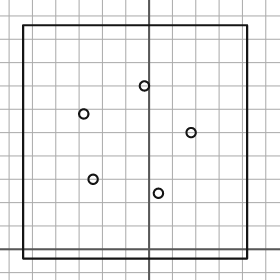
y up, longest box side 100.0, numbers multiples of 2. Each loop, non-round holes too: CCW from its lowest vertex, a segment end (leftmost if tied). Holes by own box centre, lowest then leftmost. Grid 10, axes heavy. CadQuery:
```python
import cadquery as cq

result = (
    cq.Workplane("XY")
    .moveTo(-54.0, -4.0)
    .lineTo(42.0, -4.0)
    .lineTo(42.0, 96.0)
    .lineTo(-54.0, 96.0)
    .close()
    .moveTo(4.0, 24.0)
    .circle(2.0)
    .moveTo(-24.0, 30.0)
    .circle(2.0)
    .moveTo(18.0, 50.0)
    .circle(2.0)
    .moveTo(-28.0, 58.0)
    .circle(2.0)
    .moveTo(-2.0, 70.0)
    .circle(2.0)
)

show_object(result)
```